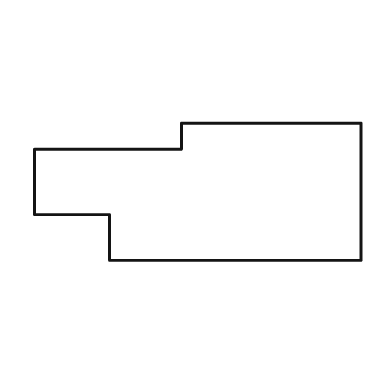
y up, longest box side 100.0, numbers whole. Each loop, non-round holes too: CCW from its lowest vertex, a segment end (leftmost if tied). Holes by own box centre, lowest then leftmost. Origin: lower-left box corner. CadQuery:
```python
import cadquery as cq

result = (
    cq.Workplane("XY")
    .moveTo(23.0, 0.0)
    .lineTo(100.0, 0.0)
    .lineTo(100.0, 42.0)
    .lineTo(45.0, 42.0)
    .lineTo(45.0, 34.0)
    .lineTo(0.0, 34.0)
    .lineTo(0.0, 14.0)
    .lineTo(23.0, 14.0)
    .close()
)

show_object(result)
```